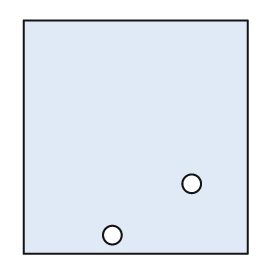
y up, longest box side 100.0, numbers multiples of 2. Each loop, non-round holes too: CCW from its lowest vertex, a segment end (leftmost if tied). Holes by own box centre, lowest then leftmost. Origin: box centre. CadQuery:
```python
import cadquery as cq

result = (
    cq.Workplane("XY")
    .moveTo(-48.0, -50.0)
    .lineTo(48.0, -50.0)
    .lineTo(48.0, 50.0)
    .lineTo(-48.0, 50.0)
    .close()
    .moveTo(-10.0, -42.0)
    .circle(4.0)
    .moveTo(24.0, -20.0)
    .circle(4.0)
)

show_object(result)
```